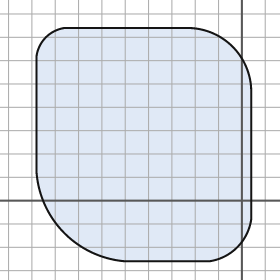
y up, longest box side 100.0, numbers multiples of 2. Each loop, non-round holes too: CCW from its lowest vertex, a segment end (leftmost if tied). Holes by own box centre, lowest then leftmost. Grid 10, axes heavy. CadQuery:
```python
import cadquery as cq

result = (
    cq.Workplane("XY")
    .moveTo(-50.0, -26.0)
    .lineTo(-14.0, -26.0)
    .threePointArc((-2.0, -20.0), (4.0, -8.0))
    .lineTo(4.0, 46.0)
    .threePointArc((-4.0, 66.0), (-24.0, 74.0))
    .lineTo(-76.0, 74.0)
    .threePointArc((-84.0, 70.0), (-88.0, 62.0))
    .lineTo(-88.0, 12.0)
    .threePointArc((-76.0, -14.0), (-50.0, -26.0))
    .close()
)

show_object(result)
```